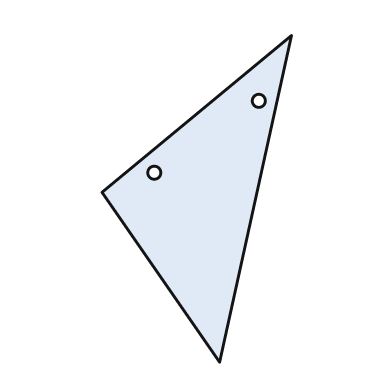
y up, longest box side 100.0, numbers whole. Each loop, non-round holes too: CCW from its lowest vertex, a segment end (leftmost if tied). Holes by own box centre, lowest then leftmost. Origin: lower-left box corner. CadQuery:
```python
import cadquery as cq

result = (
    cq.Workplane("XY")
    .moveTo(36.0, 0.0)
    .lineTo(58.0, 100.0)
    .lineTo(0.0, 52.0)
    .close()
    .moveTo(16.0, 58.0)
    .circle(2.0)
    .moveTo(48.0, 80.0)
    .circle(2.0)
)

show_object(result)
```